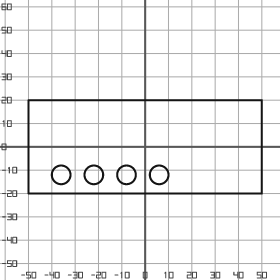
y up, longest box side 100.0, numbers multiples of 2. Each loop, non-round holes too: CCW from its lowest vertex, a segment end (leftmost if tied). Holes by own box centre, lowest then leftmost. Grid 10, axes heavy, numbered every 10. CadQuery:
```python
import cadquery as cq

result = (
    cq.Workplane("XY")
    .moveTo(-50.0, -20.0)
    .lineTo(50.0, -20.0)
    .lineTo(50.0, 20.0)
    .lineTo(-50.0, 20.0)
    .close()
    .moveTo(-36.0, -12.0)
    .circle(4.0)
    .moveTo(-22.0, -12.0)
    .circle(4.0)
    .moveTo(-8.0, -12.0)
    .circle(4.0)
    .moveTo(6.0, -12.0)
    .circle(4.0)
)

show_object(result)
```